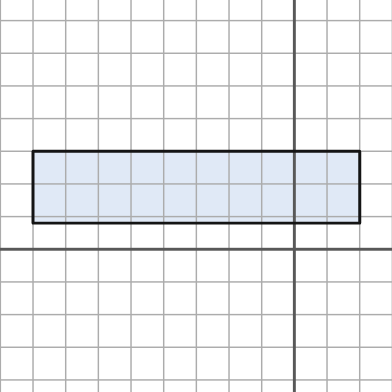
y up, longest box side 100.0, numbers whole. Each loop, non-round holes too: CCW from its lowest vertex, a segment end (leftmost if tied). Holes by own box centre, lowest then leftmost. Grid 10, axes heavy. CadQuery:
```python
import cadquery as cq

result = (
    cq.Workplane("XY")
    .moveTo(-80.0, 8.0)
    .lineTo(20.0, 8.0)
    .lineTo(20.0, 30.0)
    .lineTo(-80.0, 30.0)
    .close()
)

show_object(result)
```